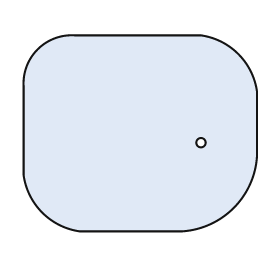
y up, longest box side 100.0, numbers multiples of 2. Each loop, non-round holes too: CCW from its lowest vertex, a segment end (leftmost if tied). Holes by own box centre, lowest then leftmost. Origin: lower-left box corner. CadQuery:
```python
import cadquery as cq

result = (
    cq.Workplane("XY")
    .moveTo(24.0, 0.0)
    .lineTo(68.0, 0.0)
    .threePointArc((90.0, 10.0), (100.0, 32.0))
    .lineTo(100.0, 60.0)
    .threePointArc((92.0, 76.0), (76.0, 84.0))
    .lineTo(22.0, 84.0)
    .threePointArc((6.0, 78.0), (0.0, 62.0))
    .lineTo(0.0, 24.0)
    .threePointArc((8.0, 8.0), (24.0, 0.0))
    .close()
    .moveTo(76.0, 38.0)
    .circle(2.0)
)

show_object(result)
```